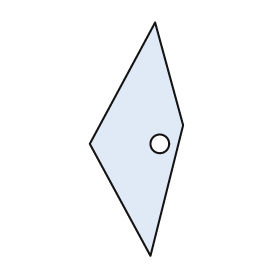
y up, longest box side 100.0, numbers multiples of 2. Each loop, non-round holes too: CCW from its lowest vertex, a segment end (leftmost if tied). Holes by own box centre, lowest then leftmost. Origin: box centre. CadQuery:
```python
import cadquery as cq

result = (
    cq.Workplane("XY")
    .moveTo(6.0, -50.0)
    .lineTo(20.0, 6.0)
    .lineTo(8.0, 50.0)
    .lineTo(-20.0, -2.0)
    .close()
    .moveTo(10.0, -2.0)
    .circle(4.0)
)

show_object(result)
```